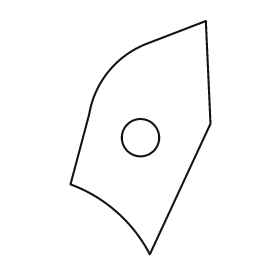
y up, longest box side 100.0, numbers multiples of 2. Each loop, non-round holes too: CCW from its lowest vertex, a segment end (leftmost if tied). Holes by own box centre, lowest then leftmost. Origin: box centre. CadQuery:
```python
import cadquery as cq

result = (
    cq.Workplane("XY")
    .moveTo(4.0, -50.0)
    .lineTo(30.0, 6.0)
    .lineTo(28.0, 50.0)
    .lineTo(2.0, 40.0)
    .threePointArc((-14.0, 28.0), (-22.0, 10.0))
    .lineTo(-30.0, -20.0)
    .threePointArc((-10.0, -32.0), (4.0, -50.0))
    .close()
    .moveTo(0.0, 0.0)
    .circle(8.0)
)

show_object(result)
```